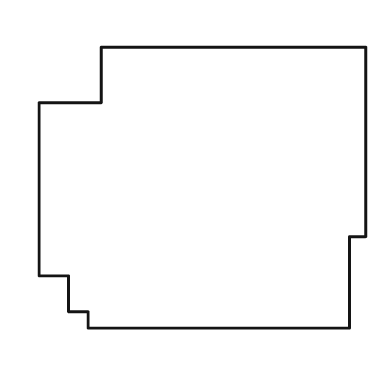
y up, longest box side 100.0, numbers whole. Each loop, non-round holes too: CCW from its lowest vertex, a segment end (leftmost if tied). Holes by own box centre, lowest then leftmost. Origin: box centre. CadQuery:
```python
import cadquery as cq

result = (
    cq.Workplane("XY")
    .moveTo(-35.0, -43.0)
    .lineTo(45.0, -43.0)
    .lineTo(45.0, -15.0)
    .lineTo(50.0, -15.0)
    .lineTo(50.0, 43.0)
    .lineTo(-31.0, 43.0)
    .lineTo(-31.0, 26.0)
    .lineTo(-50.0, 26.0)
    .lineTo(-50.0, -27.0)
    .lineTo(-41.0, -27.0)
    .lineTo(-41.0, -38.0)
    .lineTo(-35.0, -38.0)
    .close()
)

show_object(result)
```